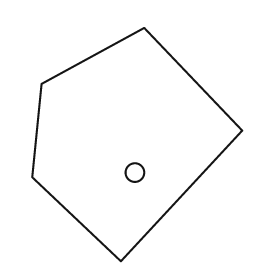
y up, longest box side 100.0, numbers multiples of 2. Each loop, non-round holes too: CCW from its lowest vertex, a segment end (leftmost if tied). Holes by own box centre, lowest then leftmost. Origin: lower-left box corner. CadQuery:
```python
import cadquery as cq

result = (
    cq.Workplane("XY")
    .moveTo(38.0, 0.0)
    .lineTo(90.0, 56.0)
    .lineTo(48.0, 100.0)
    .lineTo(4.0, 76.0)
    .lineTo(0.0, 36.0)
    .close()
    .moveTo(44.0, 38.0)
    .circle(4.0)
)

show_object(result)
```